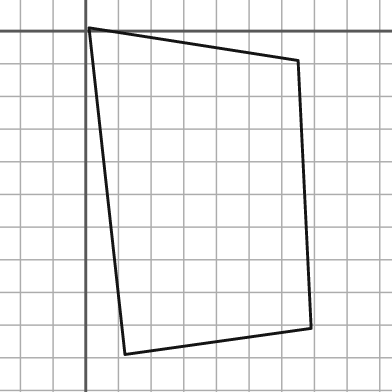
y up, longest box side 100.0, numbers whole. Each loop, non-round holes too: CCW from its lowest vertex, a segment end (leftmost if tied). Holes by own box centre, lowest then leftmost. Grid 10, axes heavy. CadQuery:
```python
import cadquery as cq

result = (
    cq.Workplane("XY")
    .moveTo(12.0, -99.0)
    .lineTo(69.0, -91.0)
    .lineTo(65.0, -9.0)
    .lineTo(1.0, 1.0)
    .close()
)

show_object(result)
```